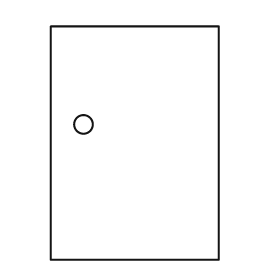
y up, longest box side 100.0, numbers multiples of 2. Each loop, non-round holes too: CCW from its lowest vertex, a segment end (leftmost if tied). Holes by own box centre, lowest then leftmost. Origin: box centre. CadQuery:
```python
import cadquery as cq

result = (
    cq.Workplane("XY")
    .moveTo(-36.0, -50.0)
    .lineTo(36.0, -50.0)
    .lineTo(36.0, 50.0)
    .lineTo(-36.0, 50.0)
    .close()
    .moveTo(-22.0, 8.0)
    .circle(4.0)
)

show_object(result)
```